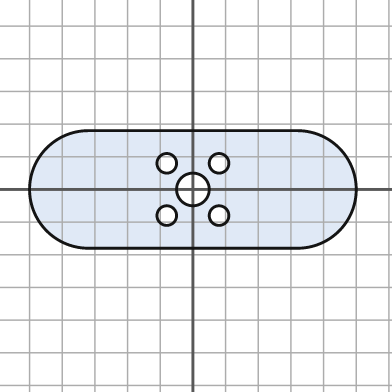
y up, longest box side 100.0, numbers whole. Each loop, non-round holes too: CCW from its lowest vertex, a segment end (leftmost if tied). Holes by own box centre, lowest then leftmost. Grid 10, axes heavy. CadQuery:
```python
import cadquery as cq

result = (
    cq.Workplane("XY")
    .moveTo(-32.0, -18.0)
    .lineTo(32.0, -18.0)
    .threePointArc((50.0, 0.0), (32.0, 18.0))
    .lineTo(-32.0, 18.0)
    .threePointArc((-50.0, 0.0), (-32.0, -18.0))
    .close()
    .moveTo(-8.0, -8.0)
    .circle(3.0)
    .moveTo(8.0, -8.0)
    .circle(3.0)
    .moveTo(0.0, 0.0)
    .circle(5.0)
    .moveTo(-8.0, 8.0)
    .circle(3.0)
    .moveTo(8.0, 8.0)
    .circle(3.0)
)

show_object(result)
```